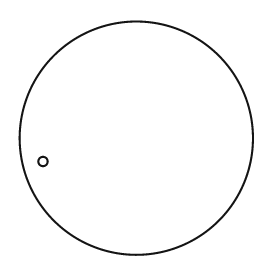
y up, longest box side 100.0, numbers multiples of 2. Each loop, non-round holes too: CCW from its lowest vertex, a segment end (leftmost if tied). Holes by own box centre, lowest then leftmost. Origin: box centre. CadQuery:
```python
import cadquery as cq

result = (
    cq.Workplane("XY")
    .moveTo(0.0, 0.0)
    .circle(50.0)
    .moveTo(-40.0, -10.0)
    .circle(2.0)
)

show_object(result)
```